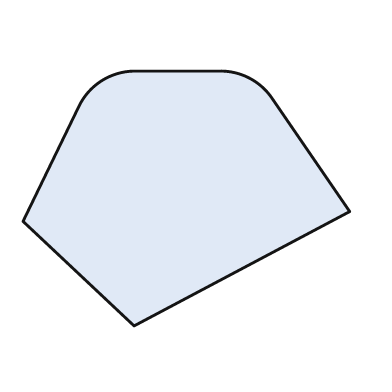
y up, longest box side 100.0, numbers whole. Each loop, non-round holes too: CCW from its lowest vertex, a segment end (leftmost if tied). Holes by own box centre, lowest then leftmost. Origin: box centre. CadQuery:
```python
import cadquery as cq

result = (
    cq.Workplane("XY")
    .moveTo(-16.0, -39.0)
    .lineTo(50.0, -4.0)
    .lineTo(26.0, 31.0)
    .threePointArc((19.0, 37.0), (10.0, 39.0))
    .lineTo(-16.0, 39.0)
    .threePointArc((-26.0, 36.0), (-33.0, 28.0))
    .lineTo(-50.0, -7.0)
    .close()
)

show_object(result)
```